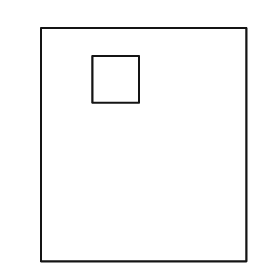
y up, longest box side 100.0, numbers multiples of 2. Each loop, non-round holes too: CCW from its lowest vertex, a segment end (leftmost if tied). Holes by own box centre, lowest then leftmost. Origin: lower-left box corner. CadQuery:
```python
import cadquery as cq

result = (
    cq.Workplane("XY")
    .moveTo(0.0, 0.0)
    .lineTo(88.0, 0.0)
    .lineTo(88.0, 100.0)
    .lineTo(0.0, 100.0)
    .close()
    .moveTo(22.0, 68.0)
    .lineTo(42.0, 68.0)
    .lineTo(42.0, 88.0)
    .lineTo(22.0, 88.0)
    .close()
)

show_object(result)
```